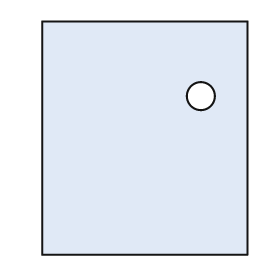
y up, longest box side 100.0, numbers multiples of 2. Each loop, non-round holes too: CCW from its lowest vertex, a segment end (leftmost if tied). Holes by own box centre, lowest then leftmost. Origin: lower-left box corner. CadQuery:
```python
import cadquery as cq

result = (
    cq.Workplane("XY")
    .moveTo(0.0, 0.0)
    .lineTo(88.0, 0.0)
    .lineTo(88.0, 100.0)
    .lineTo(0.0, 100.0)
    .close()
    .moveTo(68.0, 68.0)
    .circle(6.0)
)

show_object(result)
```